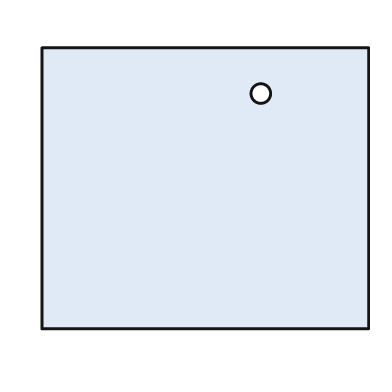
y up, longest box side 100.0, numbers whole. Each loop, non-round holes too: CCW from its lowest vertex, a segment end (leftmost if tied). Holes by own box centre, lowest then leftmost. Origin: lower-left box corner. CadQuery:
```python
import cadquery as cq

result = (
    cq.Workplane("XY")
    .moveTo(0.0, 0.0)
    .lineTo(100.0, 0.0)
    .lineTo(100.0, 86.0)
    .lineTo(0.0, 86.0)
    .close()
    .moveTo(67.0, 72.0)
    .circle(3.0)
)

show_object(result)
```